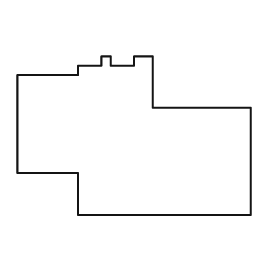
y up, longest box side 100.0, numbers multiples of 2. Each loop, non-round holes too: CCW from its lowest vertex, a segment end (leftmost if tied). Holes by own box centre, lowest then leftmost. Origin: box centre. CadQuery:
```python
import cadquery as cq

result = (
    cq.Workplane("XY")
    .moveTo(-24.0, -34.0)
    .lineTo(50.0, -34.0)
    .lineTo(50.0, 12.0)
    .lineTo(8.0, 12.0)
    .lineTo(8.0, 34.0)
    .lineTo(0.0, 34.0)
    .lineTo(0.0, 30.0)
    .lineTo(-10.0, 30.0)
    .lineTo(-10.0, 34.0)
    .lineTo(-14.0, 34.0)
    .lineTo(-14.0, 30.0)
    .lineTo(-24.0, 30.0)
    .lineTo(-24.0, 26.0)
    .lineTo(-50.0, 26.0)
    .lineTo(-50.0, -16.0)
    .lineTo(-24.0, -16.0)
    .close()
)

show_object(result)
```